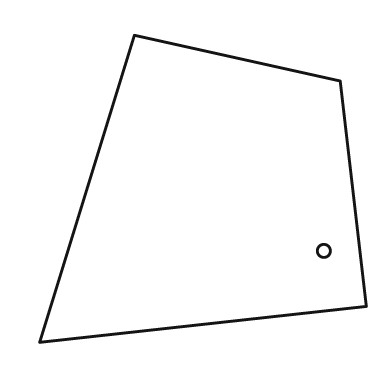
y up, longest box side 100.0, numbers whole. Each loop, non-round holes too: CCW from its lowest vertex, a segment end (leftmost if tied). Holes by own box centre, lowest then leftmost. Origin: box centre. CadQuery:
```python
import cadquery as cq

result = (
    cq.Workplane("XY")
    .moveTo(-50.0, -47.0)
    .lineTo(50.0, -36.0)
    .lineTo(42.0, 33.0)
    .lineTo(-21.0, 47.0)
    .close()
    .moveTo(37.0, -19.0)
    .circle(2.0)
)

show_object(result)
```